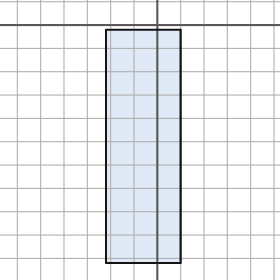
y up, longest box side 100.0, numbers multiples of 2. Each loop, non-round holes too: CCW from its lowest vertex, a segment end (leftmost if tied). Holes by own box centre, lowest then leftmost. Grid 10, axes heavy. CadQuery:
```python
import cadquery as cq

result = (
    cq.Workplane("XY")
    .moveTo(-22.0, -102.0)
    .lineTo(10.0, -102.0)
    .lineTo(10.0, -2.0)
    .lineTo(-22.0, -2.0)
    .close()
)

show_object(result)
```